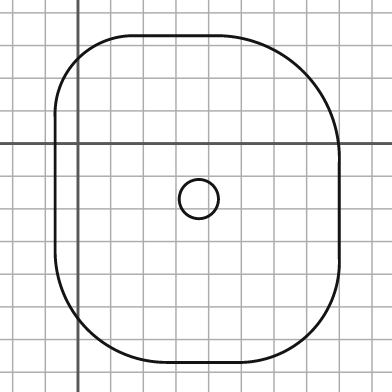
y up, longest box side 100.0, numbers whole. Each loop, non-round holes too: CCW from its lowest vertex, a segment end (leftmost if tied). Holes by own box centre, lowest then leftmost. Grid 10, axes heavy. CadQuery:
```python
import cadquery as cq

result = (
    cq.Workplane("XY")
    .moveTo(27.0, -67.0)
    .lineTo(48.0, -67.0)
    .threePointArc((71.0, -58.0), (80.0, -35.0))
    .lineTo(80.0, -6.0)
    .threePointArc((69.0, 22.0), (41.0, 33.0))
    .lineTo(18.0, 33.0)
    .threePointArc((0.0, 26.0), (-7.0, 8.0))
    .lineTo(-7.0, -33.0)
    .threePointArc((3.0, -57.0), (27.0, -67.0))
    .close()
    .moveTo(37.0, -17.0)
    .circle(6.0)
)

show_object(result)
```